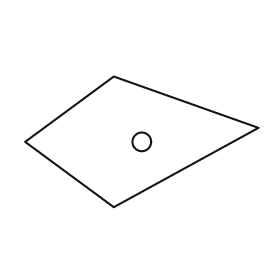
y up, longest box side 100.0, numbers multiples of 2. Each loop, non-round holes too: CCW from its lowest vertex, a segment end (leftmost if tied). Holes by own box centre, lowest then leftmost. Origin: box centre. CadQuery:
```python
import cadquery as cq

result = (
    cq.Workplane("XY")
    .moveTo(-12.0, -28.0)
    .lineTo(50.0, 6.0)
    .lineTo(-12.0, 28.0)
    .lineTo(-50.0, 0.0)
    .close()
    .moveTo(0.0, 0.0)
    .circle(4.0)
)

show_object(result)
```